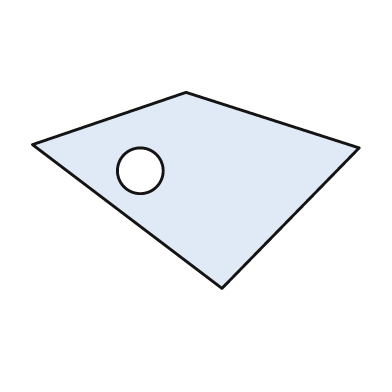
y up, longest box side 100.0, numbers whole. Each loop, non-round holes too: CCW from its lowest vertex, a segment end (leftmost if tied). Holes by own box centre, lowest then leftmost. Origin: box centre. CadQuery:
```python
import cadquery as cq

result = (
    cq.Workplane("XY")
    .moveTo(8.0, -30.0)
    .lineTo(50.0, 13.0)
    .lineTo(-3.0, 30.0)
    .lineTo(-50.0, 14.0)
    .close()
    .moveTo(-17.0, 6.0)
    .circle(7.0)
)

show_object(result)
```